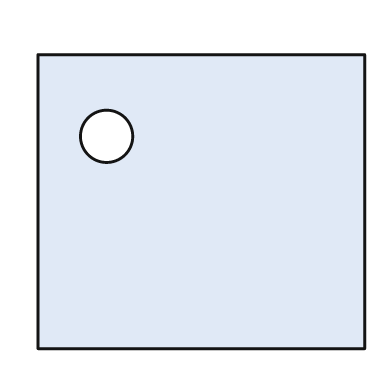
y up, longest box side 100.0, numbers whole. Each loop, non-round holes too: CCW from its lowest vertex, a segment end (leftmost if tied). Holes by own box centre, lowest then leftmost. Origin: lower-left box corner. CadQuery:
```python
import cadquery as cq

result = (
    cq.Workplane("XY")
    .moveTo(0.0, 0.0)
    .lineTo(100.0, 0.0)
    .lineTo(100.0, 90.0)
    .lineTo(0.0, 90.0)
    .close()
    .moveTo(21.0, 65.0)
    .circle(8.0)
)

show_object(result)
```